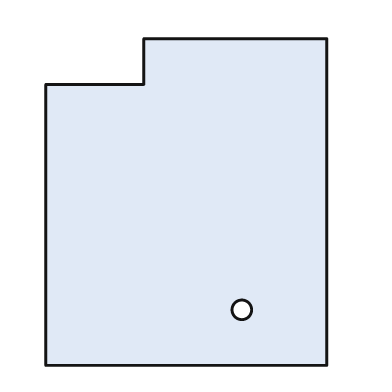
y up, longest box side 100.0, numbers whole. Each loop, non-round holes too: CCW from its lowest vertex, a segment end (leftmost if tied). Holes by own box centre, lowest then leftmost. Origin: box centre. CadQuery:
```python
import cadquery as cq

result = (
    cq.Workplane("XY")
    .moveTo(-43.0, -50.0)
    .lineTo(43.0, -50.0)
    .lineTo(43.0, 50.0)
    .lineTo(-13.0, 50.0)
    .lineTo(-13.0, 36.0)
    .lineTo(-43.0, 36.0)
    .close()
    .moveTo(17.0, -33.0)
    .circle(3.0)
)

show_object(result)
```